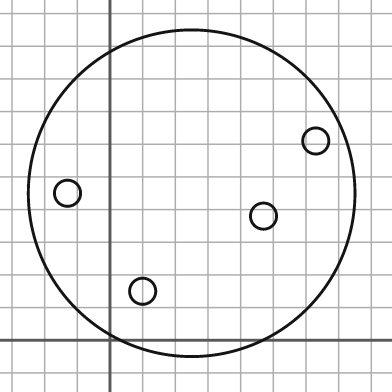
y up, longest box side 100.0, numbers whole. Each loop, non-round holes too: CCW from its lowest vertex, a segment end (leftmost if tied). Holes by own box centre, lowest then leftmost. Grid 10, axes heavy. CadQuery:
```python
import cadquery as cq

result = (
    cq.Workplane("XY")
    .moveTo(25.0, 45.0)
    .circle(50.0)
    .moveTo(10.0, 15.0)
    .circle(4.0)
    .moveTo(47.0, 38.0)
    .circle(4.0)
    .moveTo(-13.0, 45.0)
    .circle(4.0)
    .moveTo(63.0, 61.0)
    .circle(4.0)
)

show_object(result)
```